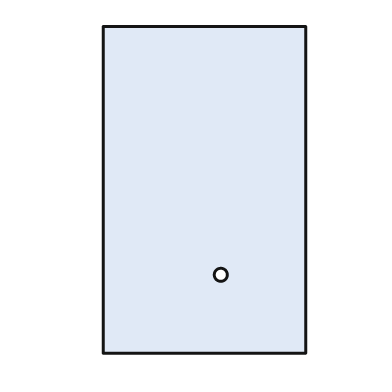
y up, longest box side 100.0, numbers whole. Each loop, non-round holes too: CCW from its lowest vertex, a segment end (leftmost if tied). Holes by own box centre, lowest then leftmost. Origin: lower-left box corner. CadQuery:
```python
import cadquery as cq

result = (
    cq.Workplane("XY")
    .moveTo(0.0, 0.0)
    .lineTo(62.0, 0.0)
    .lineTo(62.0, 100.0)
    .lineTo(0.0, 100.0)
    .close()
    .moveTo(36.0, 24.0)
    .circle(2.0)
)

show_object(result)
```